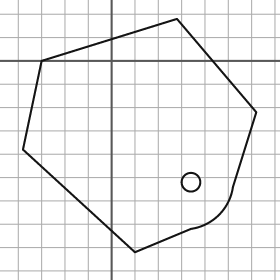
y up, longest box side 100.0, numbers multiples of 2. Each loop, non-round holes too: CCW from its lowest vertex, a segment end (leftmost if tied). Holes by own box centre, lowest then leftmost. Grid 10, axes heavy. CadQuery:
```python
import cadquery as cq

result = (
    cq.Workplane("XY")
    .moveTo(10.0, -82.0)
    .lineTo(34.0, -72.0)
    .threePointArc((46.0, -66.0), (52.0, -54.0))
    .lineTo(62.0, -22.0)
    .lineTo(28.0, 18.0)
    .lineTo(-30.0, 0.0)
    .lineTo(-38.0, -38.0)
    .close()
    .moveTo(34.0, -52.0)
    .circle(4.0)
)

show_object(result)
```